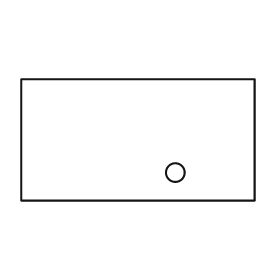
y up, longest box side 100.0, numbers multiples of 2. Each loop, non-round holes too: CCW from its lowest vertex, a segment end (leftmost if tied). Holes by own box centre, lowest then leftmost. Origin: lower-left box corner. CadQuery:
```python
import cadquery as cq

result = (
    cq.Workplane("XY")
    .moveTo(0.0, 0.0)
    .lineTo(100.0, 0.0)
    .lineTo(100.0, 52.0)
    .lineTo(0.0, 52.0)
    .close()
    .moveTo(66.0, 12.0)
    .circle(4.0)
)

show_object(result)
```